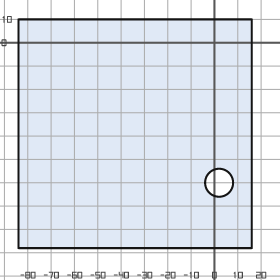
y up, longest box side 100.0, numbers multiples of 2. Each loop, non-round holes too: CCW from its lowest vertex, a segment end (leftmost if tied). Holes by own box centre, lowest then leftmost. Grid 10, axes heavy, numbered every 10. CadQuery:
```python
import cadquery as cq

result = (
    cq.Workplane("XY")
    .moveTo(-84.0, -88.0)
    .lineTo(16.0, -88.0)
    .lineTo(16.0, 10.0)
    .lineTo(-84.0, 10.0)
    .close()
    .moveTo(2.0, -60.0)
    .circle(6.0)
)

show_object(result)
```